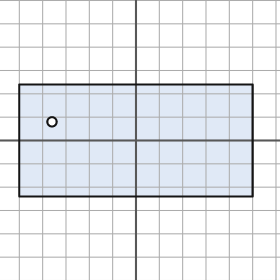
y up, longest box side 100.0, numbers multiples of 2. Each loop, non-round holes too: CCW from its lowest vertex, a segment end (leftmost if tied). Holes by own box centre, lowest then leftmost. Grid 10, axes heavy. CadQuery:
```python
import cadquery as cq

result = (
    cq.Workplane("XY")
    .moveTo(-50.0, -24.0)
    .lineTo(50.0, -24.0)
    .lineTo(50.0, 24.0)
    .lineTo(-50.0, 24.0)
    .close()
    .moveTo(-36.0, 8.0)
    .circle(2.0)
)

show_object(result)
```